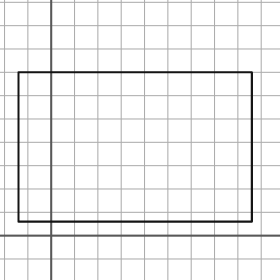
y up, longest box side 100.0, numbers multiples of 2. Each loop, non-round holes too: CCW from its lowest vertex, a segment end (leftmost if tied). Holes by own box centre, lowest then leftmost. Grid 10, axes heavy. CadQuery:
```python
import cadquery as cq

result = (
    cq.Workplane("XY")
    .moveTo(-14.0, 6.0)
    .lineTo(86.0, 6.0)
    .lineTo(86.0, 70.0)
    .lineTo(-14.0, 70.0)
    .close()
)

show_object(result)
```